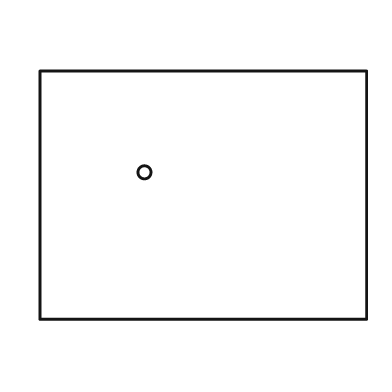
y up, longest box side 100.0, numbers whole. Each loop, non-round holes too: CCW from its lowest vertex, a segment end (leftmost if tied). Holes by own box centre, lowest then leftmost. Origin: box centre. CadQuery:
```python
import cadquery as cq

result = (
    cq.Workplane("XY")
    .moveTo(-50.0, -38.0)
    .lineTo(50.0, -38.0)
    .lineTo(50.0, 38.0)
    .lineTo(-50.0, 38.0)
    .close()
    .moveTo(-18.0, 7.0)
    .circle(2.0)
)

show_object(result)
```